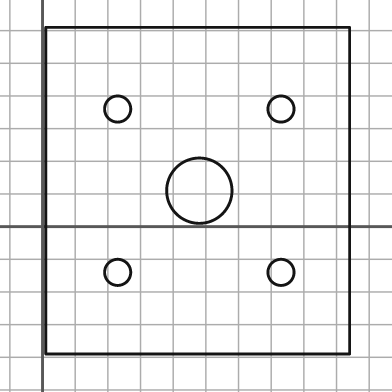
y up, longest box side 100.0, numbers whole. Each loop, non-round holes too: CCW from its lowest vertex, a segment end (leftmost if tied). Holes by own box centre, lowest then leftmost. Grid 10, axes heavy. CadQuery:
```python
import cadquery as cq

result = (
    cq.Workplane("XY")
    .moveTo(1.0, -39.0)
    .lineTo(94.0, -39.0)
    .lineTo(94.0, 61.0)
    .lineTo(1.0, 61.0)
    .close()
    .moveTo(23.0, -14.0)
    .circle(4.0)
    .moveTo(73.0, -14.0)
    .circle(4.0)
    .moveTo(48.0, 11.0)
    .circle(10.0)
    .moveTo(23.0, 36.0)
    .circle(4.0)
    .moveTo(73.0, 36.0)
    .circle(4.0)
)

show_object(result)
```